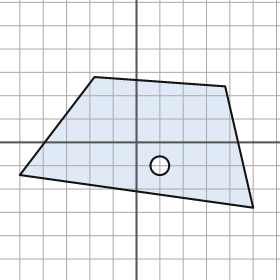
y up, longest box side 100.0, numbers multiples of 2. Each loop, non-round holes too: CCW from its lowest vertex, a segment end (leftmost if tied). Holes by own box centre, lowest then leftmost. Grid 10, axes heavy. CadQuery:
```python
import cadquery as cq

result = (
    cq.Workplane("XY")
    .moveTo(50.0, -28.0)
    .lineTo(38.0, 24.0)
    .lineTo(-18.0, 28.0)
    .lineTo(-50.0, -14.0)
    .close()
    .moveTo(10.0, -10.0)
    .circle(4.0)
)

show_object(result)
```